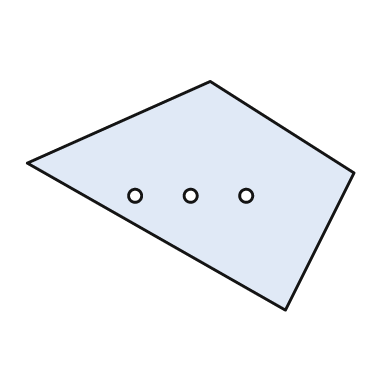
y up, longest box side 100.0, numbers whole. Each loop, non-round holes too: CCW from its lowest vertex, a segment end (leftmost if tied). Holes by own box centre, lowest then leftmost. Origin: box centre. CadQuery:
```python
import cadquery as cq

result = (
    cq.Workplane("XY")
    .moveTo(29.0, -35.0)
    .lineTo(50.0, 7.0)
    .lineTo(6.0, 35.0)
    .lineTo(-50.0, 10.0)
    .close()
    .moveTo(-17.0, 0.0)
    .circle(2.0)
    .moveTo(0.0, 0.0)
    .circle(2.0)
    .moveTo(17.0, 0.0)
    .circle(2.0)
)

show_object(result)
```